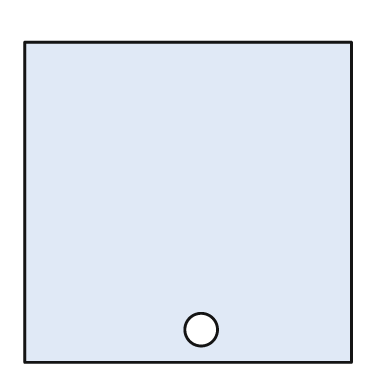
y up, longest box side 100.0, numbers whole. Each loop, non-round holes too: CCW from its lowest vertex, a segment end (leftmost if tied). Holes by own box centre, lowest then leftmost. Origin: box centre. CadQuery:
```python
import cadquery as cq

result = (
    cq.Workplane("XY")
    .moveTo(-50.0, -49.0)
    .lineTo(50.0, -49.0)
    .lineTo(50.0, 49.0)
    .lineTo(-50.0, 49.0)
    .close()
    .moveTo(4.0, -39.0)
    .circle(5.0)
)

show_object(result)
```